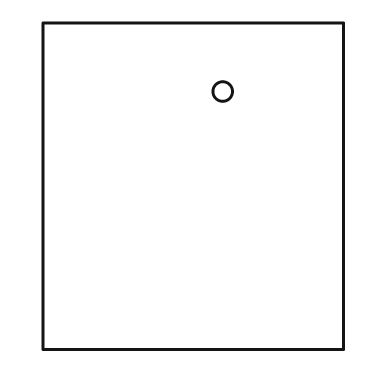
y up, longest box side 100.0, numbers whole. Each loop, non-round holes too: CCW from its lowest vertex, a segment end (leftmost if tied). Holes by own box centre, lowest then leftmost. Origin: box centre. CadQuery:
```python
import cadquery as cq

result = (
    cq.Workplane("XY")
    .moveTo(-46.0, -50.0)
    .lineTo(46.0, -50.0)
    .lineTo(46.0, 50.0)
    .lineTo(-46.0, 50.0)
    .close()
    .moveTo(9.0, 29.0)
    .circle(3.0)
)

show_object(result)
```